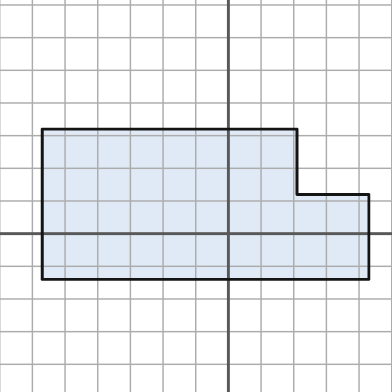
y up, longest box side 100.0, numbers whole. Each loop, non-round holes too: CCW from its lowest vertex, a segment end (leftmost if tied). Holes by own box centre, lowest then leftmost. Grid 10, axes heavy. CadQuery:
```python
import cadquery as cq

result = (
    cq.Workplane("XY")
    .moveTo(-57.0, -14.0)
    .lineTo(43.0, -14.0)
    .lineTo(43.0, 12.0)
    .lineTo(21.0, 12.0)
    .lineTo(21.0, 32.0)
    .lineTo(-57.0, 32.0)
    .close()
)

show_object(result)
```